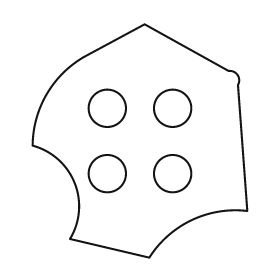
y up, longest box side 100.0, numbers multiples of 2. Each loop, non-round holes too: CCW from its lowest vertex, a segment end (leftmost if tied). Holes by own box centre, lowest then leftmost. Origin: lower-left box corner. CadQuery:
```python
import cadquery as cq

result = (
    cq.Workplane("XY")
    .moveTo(50.0, 0.0)
    .threePointArc((68.0, 16.0), (92.0, 20.0))
    .lineTo(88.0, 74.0)
    .threePointArc((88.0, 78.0), (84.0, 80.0))
    .lineTo(48.0, 100.0)
    .lineTo(22.0, 86.0)
    .threePointArc((6.0, 70.0), (0.0, 48.0))
    .threePointArc((18.0, 32.0), (16.0, 8.0))
    .close()
    .moveTo(32.0, 36.0)
    .circle(8.0)
    .moveTo(60.0, 36.0)
    .circle(8.0)
    .moveTo(32.0, 64.0)
    .circle(8.0)
    .moveTo(60.0, 64.0)
    .circle(8.0)
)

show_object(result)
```